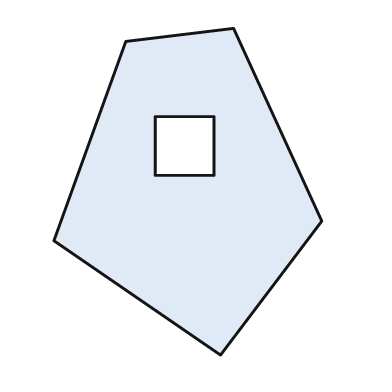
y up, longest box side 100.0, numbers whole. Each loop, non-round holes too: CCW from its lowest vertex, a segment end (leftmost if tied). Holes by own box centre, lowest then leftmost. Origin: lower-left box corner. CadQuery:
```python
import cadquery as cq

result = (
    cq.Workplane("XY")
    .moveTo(51.0, 0.0)
    .lineTo(82.0, 41.0)
    .lineTo(55.0, 100.0)
    .lineTo(22.0, 96.0)
    .lineTo(0.0, 35.0)
    .close()
    .moveTo(31.0, 55.0)
    .lineTo(49.0, 55.0)
    .lineTo(49.0, 73.0)
    .lineTo(31.0, 73.0)
    .close()
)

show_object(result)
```